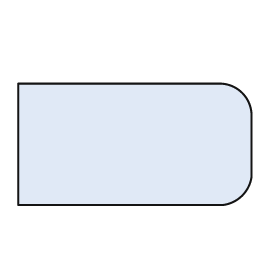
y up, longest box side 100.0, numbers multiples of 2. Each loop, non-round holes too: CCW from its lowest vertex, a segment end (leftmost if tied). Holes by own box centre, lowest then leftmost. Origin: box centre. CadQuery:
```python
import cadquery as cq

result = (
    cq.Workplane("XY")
    .moveTo(-50.0, -26.0)
    .lineTo(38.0, -26.0)
    .threePointArc((46.0, -22.0), (50.0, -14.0))
    .lineTo(50.0, 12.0)
    .threePointArc((46.0, 22.0), (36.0, 26.0))
    .lineTo(-50.0, 26.0)
    .close()
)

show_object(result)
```